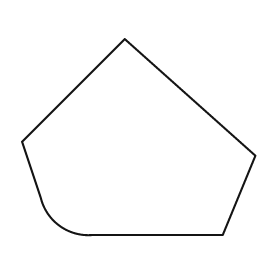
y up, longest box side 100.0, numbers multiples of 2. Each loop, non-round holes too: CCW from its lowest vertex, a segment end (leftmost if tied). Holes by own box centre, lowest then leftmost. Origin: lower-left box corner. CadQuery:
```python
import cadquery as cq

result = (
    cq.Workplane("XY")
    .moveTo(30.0, 0.0)
    .lineTo(86.0, 0.0)
    .lineTo(100.0, 34.0)
    .lineTo(44.0, 84.0)
    .lineTo(0.0, 40.0)
    .lineTo(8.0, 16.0)
    .threePointArc((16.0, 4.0), (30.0, 0.0))
    .close()
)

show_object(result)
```